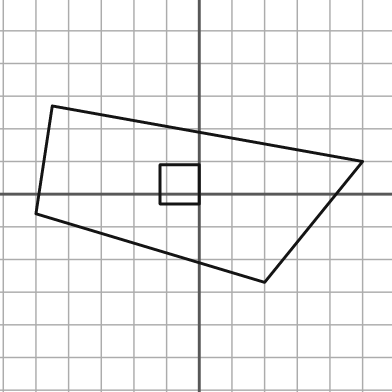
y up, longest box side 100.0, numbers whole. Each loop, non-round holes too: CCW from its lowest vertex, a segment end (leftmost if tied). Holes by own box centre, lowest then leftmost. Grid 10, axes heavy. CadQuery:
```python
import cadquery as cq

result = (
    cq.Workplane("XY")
    .moveTo(20.0, -27.0)
    .lineTo(50.0, 10.0)
    .lineTo(-45.0, 27.0)
    .lineTo(-50.0, -6.0)
    .close()
    .moveTo(-12.0, -3.0)
    .lineTo(0.0, -3.0)
    .lineTo(0.0, 9.0)
    .lineTo(-12.0, 9.0)
    .close()
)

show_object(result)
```